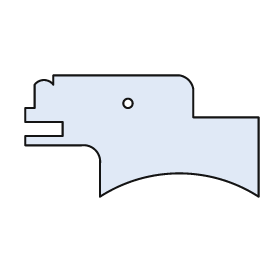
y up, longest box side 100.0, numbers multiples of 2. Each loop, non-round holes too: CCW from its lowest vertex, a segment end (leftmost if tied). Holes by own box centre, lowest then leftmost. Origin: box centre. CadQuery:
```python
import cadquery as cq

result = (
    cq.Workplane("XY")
    .moveTo(-18.0, -26.0)
    .threePointArc((16.0, -16.0), (50.0, -26.0))
    .lineTo(50.0, 8.0)
    .lineTo(22.0, 8.0)
    .lineTo(22.0, 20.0)
    .threePointArc((20.0, 24.0), (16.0, 26.0))
    .lineTo(-38.0, 26.0)
    .lineTo(-38.0, 22.0)
    .threePointArc((-42.0, 24.0), (-46.0, 22.0))
    .lineTo(-46.0, 12.0)
    .lineTo(-50.0, 12.0)
    .lineTo(-50.0, 6.0)
    .lineTo(-34.0, 6.0)
    .lineTo(-34.0, 0.0)
    .lineTo(-50.0, 0.0)
    .lineTo(-50.0, -4.0)
    .lineTo(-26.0, -4.0)
    .threePointArc((-20.0, -6.0), (-18.0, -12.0))
    .close()
    .moveTo(-6.0, 14.0)
    .circle(2.0)
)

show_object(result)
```